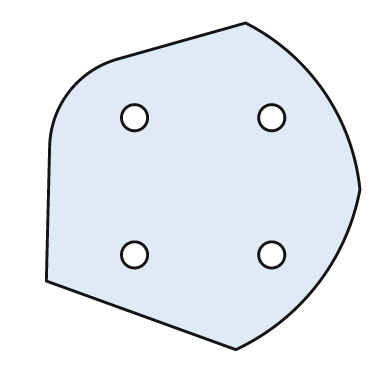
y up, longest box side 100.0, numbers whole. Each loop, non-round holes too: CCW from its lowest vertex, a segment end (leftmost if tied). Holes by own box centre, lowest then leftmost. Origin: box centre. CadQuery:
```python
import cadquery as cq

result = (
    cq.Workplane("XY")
    .moveTo(10.0, -50.0)
    .threePointArc((35.0, -30.0), (48.0, -1.0))
    .threePointArc((37.0, 29.0), (13.0, 50.0))
    .lineTo(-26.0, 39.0)
    .threePointArc((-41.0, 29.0), (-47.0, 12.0))
    .lineTo(-48.0, -29.0)
    .close()
    .moveTo(-21.0, -21.0)
    .circle(4.0)
    .moveTo(21.0, -21.0)
    .circle(4.0)
    .moveTo(-21.0, 21.0)
    .circle(4.0)
    .moveTo(21.0, 21.0)
    .circle(4.0)
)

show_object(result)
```